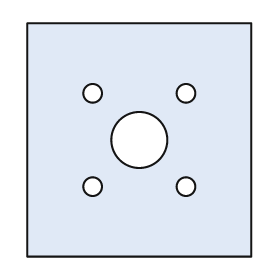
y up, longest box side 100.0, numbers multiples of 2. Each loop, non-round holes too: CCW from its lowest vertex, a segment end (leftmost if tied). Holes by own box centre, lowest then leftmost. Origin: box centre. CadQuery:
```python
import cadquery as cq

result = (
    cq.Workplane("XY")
    .moveTo(-48.0, -50.0)
    .lineTo(48.0, -50.0)
    .lineTo(48.0, 50.0)
    .lineTo(-48.0, 50.0)
    .close()
    .moveTo(-20.0, -20.0)
    .circle(4.0)
    .moveTo(20.0, -20.0)
    .circle(4.0)
    .moveTo(0.0, 0.0)
    .circle(12.0)
    .moveTo(-20.0, 20.0)
    .circle(4.0)
    .moveTo(20.0, 20.0)
    .circle(4.0)
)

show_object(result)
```